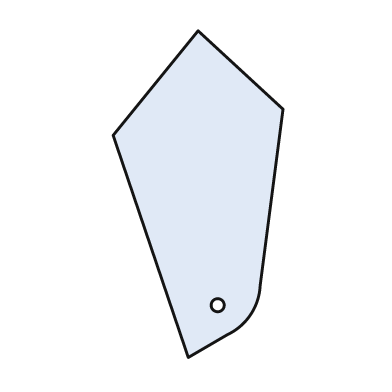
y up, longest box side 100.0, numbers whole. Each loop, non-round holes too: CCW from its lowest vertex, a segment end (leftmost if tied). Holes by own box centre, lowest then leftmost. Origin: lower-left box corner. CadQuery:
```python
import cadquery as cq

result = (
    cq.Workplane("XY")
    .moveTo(23.0, 0.0)
    .lineTo(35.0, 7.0)
    .threePointArc((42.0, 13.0), (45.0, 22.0))
    .lineTo(52.0, 76.0)
    .lineTo(26.0, 100.0)
    .lineTo(0.0, 68.0)
    .close()
    .moveTo(32.0, 16.0)
    .circle(2.0)
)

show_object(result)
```